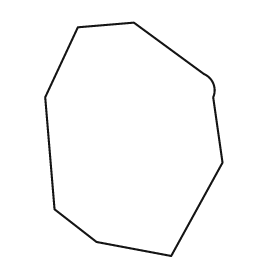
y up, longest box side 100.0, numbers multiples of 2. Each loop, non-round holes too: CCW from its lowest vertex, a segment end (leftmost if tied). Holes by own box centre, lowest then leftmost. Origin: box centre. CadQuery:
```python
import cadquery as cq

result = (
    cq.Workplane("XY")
    .moveTo(16.0, -50.0)
    .lineTo(38.0, -10.0)
    .lineTo(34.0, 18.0)
    .threePointArc((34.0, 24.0), (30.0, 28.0))
    .lineTo(0.0, 50.0)
    .lineTo(-24.0, 48.0)
    .lineTo(-38.0, 18.0)
    .lineTo(-34.0, -30.0)
    .lineTo(-16.0, -44.0)
    .close()
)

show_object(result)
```